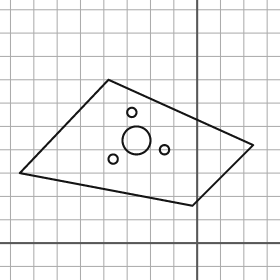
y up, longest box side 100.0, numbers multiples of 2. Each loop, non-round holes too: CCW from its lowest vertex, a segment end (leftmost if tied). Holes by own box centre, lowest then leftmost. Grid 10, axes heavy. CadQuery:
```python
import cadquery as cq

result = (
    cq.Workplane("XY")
    .moveTo(-2.0, 16.0)
    .lineTo(24.0, 42.0)
    .lineTo(-38.0, 70.0)
    .lineTo(-76.0, 30.0)
    .close()
    .moveTo(-36.0, 36.0)
    .circle(2.0)
    .moveTo(-14.0, 40.0)
    .circle(2.0)
    .moveTo(-26.0, 44.0)
    .circle(6.0)
    .moveTo(-28.0, 56.0)
    .circle(2.0)
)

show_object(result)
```